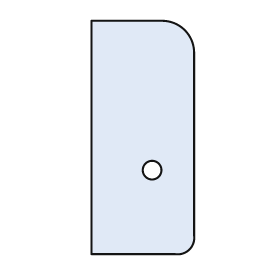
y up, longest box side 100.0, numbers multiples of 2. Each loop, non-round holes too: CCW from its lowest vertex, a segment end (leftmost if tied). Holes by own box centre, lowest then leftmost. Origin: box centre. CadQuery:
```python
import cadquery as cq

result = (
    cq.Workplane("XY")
    .moveTo(-22.0, -50.0)
    .lineTo(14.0, -50.0)
    .threePointArc((20.0, -48.0), (22.0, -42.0))
    .lineTo(22.0, 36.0)
    .threePointArc((18.0, 46.0), (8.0, 50.0))
    .lineTo(-22.0, 50.0)
    .close()
    .moveTo(4.0, -14.0)
    .circle(4.0)
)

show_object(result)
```